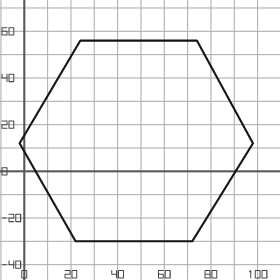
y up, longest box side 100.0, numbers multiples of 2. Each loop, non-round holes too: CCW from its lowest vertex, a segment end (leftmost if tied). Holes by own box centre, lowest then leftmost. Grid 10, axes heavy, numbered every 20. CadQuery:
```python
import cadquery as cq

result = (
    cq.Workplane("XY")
    .moveTo(22.0, -30.0)
    .lineTo(72.0, -30.0)
    .lineTo(98.0, 12.0)
    .lineTo(74.0, 56.0)
    .lineTo(24.0, 56.0)
    .lineTo(-2.0, 12.0)
    .close()
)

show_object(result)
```